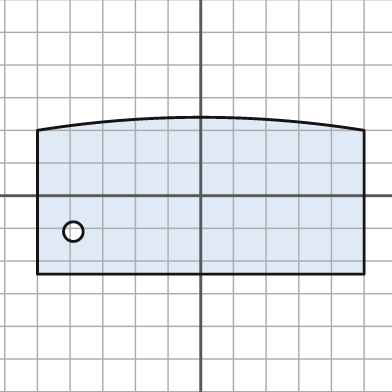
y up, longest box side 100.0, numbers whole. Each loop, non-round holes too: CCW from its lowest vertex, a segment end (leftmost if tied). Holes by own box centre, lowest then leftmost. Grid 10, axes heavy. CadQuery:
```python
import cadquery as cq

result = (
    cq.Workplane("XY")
    .moveTo(-50.0, -24.0)
    .lineTo(50.0, -24.0)
    .lineTo(50.0, 20.0)
    .threePointArc((0.0, 24.0), (-50.0, 20.0))
    .close()
    .moveTo(-39.0, -11.0)
    .circle(3.0)
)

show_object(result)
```